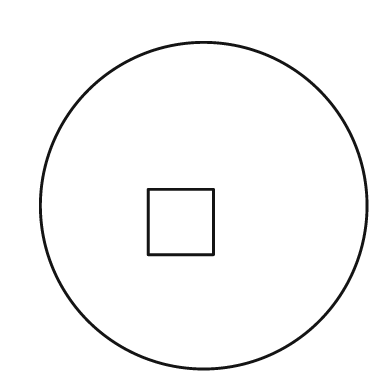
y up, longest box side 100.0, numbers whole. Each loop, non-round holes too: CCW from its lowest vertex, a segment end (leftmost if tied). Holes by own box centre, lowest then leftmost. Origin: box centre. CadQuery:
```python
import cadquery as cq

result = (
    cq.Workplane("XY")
    .moveTo(0.0, 0.0)
    .circle(50.0)
    .moveTo(-17.0, -15.0)
    .lineTo(3.0, -15.0)
    .lineTo(3.0, 5.0)
    .lineTo(-17.0, 5.0)
    .close()
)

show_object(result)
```